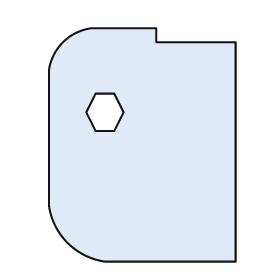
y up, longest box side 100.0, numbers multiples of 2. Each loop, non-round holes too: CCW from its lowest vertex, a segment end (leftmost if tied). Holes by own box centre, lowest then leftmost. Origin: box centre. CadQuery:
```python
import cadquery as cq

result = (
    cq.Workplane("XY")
    .moveTo(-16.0, -50.0)
    .lineTo(40.0, -50.0)
    .lineTo(40.0, 44.0)
    .lineTo(6.0, 44.0)
    .lineTo(6.0, 50.0)
    .lineTo(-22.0, 50.0)
    .threePointArc((-34.0, 44.0), (-40.0, 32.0))
    .lineTo(-40.0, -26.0)
    .threePointArc((-32.0, -42.0), (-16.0, -50.0))
    .close()
    .moveTo(-20.0, 6.0)
    .lineTo(-12.0, 6.0)
    .lineTo(-8.0, 14.0)
    .lineTo(-12.0, 22.0)
    .lineTo(-20.0, 22.0)
    .lineTo(-24.0, 14.0)
    .close()
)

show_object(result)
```